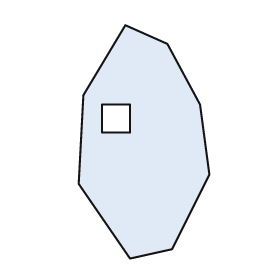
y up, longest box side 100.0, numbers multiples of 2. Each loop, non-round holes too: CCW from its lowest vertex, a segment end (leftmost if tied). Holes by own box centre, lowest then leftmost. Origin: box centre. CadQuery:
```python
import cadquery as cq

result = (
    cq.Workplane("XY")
    .moveTo(-6.0, -50.0)
    .lineTo(12.0, -46.0)
    .lineTo(28.0, -14.0)
    .lineTo(24.0, 16.0)
    .lineTo(10.0, 42.0)
    .lineTo(-8.0, 50.0)
    .lineTo(-26.0, 20.0)
    .lineTo(-28.0, -18.0)
    .close()
    .moveTo(-18.0, 4.0)
    .lineTo(-6.0, 4.0)
    .lineTo(-6.0, 16.0)
    .lineTo(-18.0, 16.0)
    .close()
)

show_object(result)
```